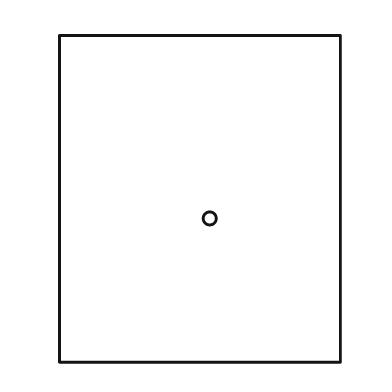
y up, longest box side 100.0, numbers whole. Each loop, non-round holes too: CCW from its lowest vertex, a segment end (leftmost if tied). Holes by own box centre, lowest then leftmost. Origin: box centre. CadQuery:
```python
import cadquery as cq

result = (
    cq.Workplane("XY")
    .moveTo(-43.0, -50.0)
    .lineTo(43.0, -50.0)
    .lineTo(43.0, 50.0)
    .lineTo(-43.0, 50.0)
    .close()
    .moveTo(3.0, -6.0)
    .circle(2.0)
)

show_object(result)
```